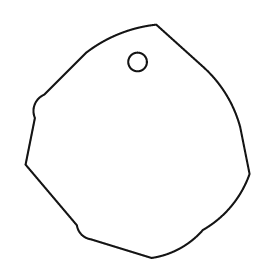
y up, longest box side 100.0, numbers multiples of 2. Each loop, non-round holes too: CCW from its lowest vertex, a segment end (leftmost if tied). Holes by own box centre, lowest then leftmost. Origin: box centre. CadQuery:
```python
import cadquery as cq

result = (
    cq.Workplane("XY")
    .moveTo(6.0, -50.0)
    .threePointArc((18.0, -46.0), (28.0, -38.0))
    .threePointArc((40.0, -28.0), (48.0, -14.0))
    .lineTo(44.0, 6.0)
    .threePointArc((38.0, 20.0), (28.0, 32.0))
    .lineTo(8.0, 50.0)
    .threePointArc((-8.0, 46.0), (-22.0, 38.0))
    .lineTo(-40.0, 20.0)
    .threePointArc((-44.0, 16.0), (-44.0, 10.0))
    .lineTo(-48.0, -10.0)
    .lineTo(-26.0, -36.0)
    .threePointArc((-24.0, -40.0), (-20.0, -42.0))
    .close()
    .moveTo(0.0, 34.0)
    .circle(4.0)
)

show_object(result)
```